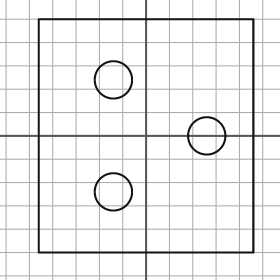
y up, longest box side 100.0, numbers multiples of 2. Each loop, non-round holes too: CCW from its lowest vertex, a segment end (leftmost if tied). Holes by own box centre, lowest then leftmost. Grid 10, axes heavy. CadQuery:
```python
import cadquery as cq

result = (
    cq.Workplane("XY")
    .moveTo(-46.0, -50.0)
    .lineTo(46.0, -50.0)
    .lineTo(46.0, 50.0)
    .lineTo(-46.0, 50.0)
    .close()
    .moveTo(-14.0, -24.0)
    .circle(8.0)
    .moveTo(26.0, 0.0)
    .circle(8.0)
    .moveTo(-14.0, 24.0)
    .circle(8.0)
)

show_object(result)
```